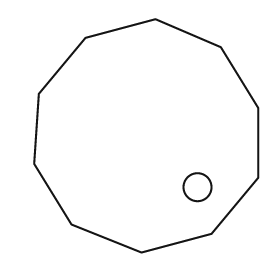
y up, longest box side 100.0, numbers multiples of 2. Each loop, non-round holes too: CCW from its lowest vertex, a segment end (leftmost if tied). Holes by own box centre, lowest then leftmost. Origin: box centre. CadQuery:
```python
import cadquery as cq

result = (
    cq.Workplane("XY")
    .moveTo(-2.0, -50.0)
    .lineTo(28.0, -42.0)
    .lineTo(48.0, -18.0)
    .lineTo(48.0, 12.0)
    .lineTo(32.0, 38.0)
    .lineTo(4.0, 50.0)
    .lineTo(-26.0, 42.0)
    .lineTo(-46.0, 18.0)
    .lineTo(-48.0, -12.0)
    .lineTo(-32.0, -38.0)
    .close()
    .moveTo(22.0, -22.0)
    .circle(6.0)
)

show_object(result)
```